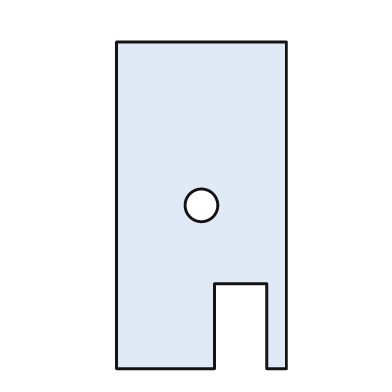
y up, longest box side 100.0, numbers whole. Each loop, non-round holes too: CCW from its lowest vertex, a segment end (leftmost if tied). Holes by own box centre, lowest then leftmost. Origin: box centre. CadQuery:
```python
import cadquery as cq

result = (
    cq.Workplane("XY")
    .moveTo(-26.0, -50.0)
    .lineTo(4.0, -50.0)
    .lineTo(4.0, -24.0)
    .lineTo(20.0, -24.0)
    .lineTo(20.0, -50.0)
    .lineTo(26.0, -50.0)
    .lineTo(26.0, 50.0)
    .lineTo(-26.0, 50.0)
    .close()
    .moveTo(0.0, 0.0)
    .circle(5.0)
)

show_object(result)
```